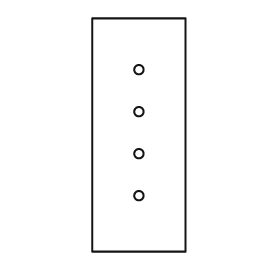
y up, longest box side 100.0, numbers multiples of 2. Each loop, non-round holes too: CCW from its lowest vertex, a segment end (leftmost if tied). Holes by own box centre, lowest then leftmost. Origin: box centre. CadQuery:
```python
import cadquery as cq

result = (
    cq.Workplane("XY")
    .moveTo(-20.0, -50.0)
    .lineTo(20.0, -50.0)
    .lineTo(20.0, 50.0)
    .lineTo(-20.0, 50.0)
    .close()
    .moveTo(0.0, -26.0)
    .circle(2.0)
    .moveTo(0.0, -8.0)
    .circle(2.0)
    .moveTo(0.0, 10.0)
    .circle(2.0)
    .moveTo(0.0, 28.0)
    .circle(2.0)
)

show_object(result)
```